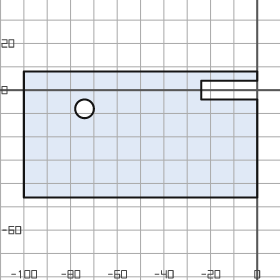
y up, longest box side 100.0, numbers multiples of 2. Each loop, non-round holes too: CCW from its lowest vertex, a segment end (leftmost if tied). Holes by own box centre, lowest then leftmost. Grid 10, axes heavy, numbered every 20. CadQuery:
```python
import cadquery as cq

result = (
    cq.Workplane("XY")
    .moveTo(-100.0, -46.0)
    .lineTo(0.0, -46.0)
    .lineTo(0.0, -4.0)
    .lineTo(-24.0, -4.0)
    .lineTo(-24.0, 4.0)
    .lineTo(0.0, 4.0)
    .lineTo(0.0, 8.0)
    .lineTo(-100.0, 8.0)
    .close()
    .moveTo(-74.0, -8.0)
    .circle(4.0)
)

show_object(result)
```